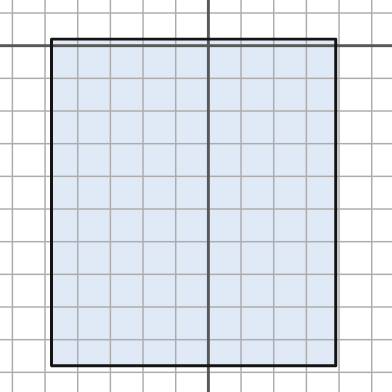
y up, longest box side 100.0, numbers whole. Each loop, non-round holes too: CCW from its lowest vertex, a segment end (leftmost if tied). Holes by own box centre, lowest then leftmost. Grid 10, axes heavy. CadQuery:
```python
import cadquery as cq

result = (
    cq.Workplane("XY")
    .moveTo(-48.0, -98.0)
    .lineTo(39.0, -98.0)
    .lineTo(39.0, 2.0)
    .lineTo(-48.0, 2.0)
    .close()
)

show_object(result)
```